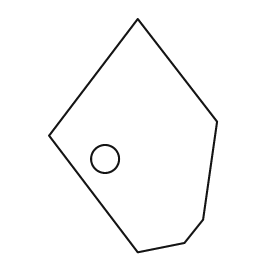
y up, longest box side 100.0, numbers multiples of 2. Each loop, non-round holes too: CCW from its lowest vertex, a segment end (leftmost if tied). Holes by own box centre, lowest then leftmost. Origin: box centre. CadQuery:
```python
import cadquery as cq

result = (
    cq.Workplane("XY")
    .moveTo(2.0, -50.0)
    .lineTo(22.0, -46.0)
    .lineTo(30.0, -36.0)
    .lineTo(36.0, 6.0)
    .lineTo(2.0, 50.0)
    .lineTo(-36.0, 0.0)
    .close()
    .moveTo(-12.0, -10.0)
    .circle(6.0)
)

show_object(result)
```